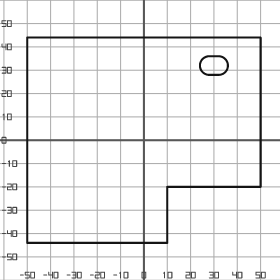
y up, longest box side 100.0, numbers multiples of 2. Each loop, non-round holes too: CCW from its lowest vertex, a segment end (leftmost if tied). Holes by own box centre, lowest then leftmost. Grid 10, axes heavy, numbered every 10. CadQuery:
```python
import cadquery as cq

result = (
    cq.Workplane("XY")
    .moveTo(-50.0, -44.0)
    .lineTo(10.0, -44.0)
    .lineTo(10.0, -20.0)
    .lineTo(50.0, -20.0)
    .lineTo(50.0, 44.0)
    .lineTo(-50.0, 44.0)
    .close()
    .moveTo(28.0, 28.0)
    .lineTo(32.0, 28.0)
    .threePointArc((36.0, 32.0), (32.0, 36.0))
    .lineTo(28.0, 36.0)
    .threePointArc((24.0, 32.0), (28.0, 28.0))
    .close()
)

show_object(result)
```